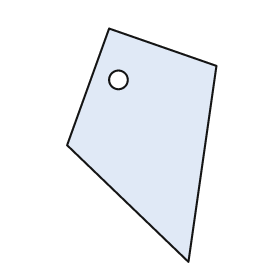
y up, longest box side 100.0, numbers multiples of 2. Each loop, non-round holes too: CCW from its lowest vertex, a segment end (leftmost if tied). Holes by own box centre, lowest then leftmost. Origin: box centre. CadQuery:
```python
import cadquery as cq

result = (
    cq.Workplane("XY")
    .moveTo(20.0, -50.0)
    .lineTo(32.0, 34.0)
    .lineTo(-14.0, 50.0)
    .lineTo(-32.0, 0.0)
    .close()
    .moveTo(-10.0, 28.0)
    .circle(4.0)
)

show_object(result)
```